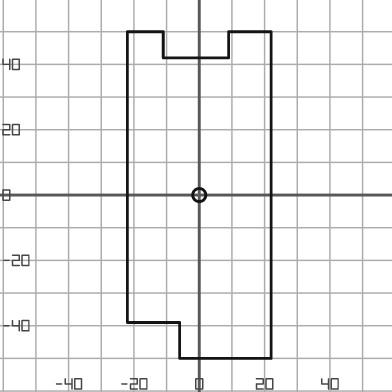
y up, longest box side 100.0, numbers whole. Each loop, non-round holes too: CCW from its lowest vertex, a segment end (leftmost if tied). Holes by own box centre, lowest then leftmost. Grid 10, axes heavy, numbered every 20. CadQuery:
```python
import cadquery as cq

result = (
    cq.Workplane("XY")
    .moveTo(-6.0, -50.0)
    .lineTo(22.0, -50.0)
    .lineTo(22.0, 50.0)
    .lineTo(9.0, 50.0)
    .lineTo(9.0, 42.0)
    .lineTo(-11.0, 42.0)
    .lineTo(-11.0, 50.0)
    .lineTo(-22.0, 50.0)
    .lineTo(-22.0, -39.0)
    .lineTo(-6.0, -39.0)
    .close()
    .moveTo(0.0, 0.0)
    .circle(2.0)
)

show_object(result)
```